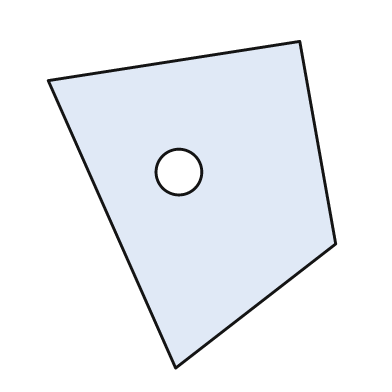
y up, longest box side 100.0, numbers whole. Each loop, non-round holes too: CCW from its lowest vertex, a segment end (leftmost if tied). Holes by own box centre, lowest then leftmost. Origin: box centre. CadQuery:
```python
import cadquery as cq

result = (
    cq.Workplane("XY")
    .moveTo(-5.0, -50.0)
    .lineTo(44.0, -12.0)
    .lineTo(33.0, 50.0)
    .lineTo(-44.0, 38.0)
    .close()
    .moveTo(-4.0, 10.0)
    .circle(7.0)
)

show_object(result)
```